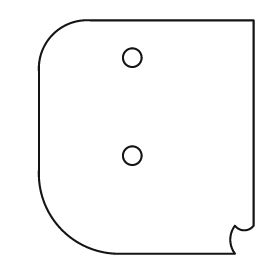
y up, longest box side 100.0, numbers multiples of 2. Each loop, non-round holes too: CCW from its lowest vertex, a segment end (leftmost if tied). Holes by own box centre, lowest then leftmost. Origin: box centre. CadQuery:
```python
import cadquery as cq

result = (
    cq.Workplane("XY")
    .moveTo(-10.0, -50.0)
    .lineTo(38.0, -50.0)
    .threePointArc((36.0, -44.0), (38.0, -38.0))
    .threePointArc((42.0, -40.0), (46.0, -38.0))
    .lineTo(46.0, 50.0)
    .lineTo(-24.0, 50.0)
    .threePointArc((-40.0, 44.0), (-46.0, 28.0))
    .lineTo(-46.0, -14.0)
    .threePointArc((-36.0, -40.0), (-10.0, -50.0))
    .close()
    .moveTo(-6.0, -8.0)
    .circle(4.0)
    .moveTo(-6.0, 34.0)
    .circle(4.0)
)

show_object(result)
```